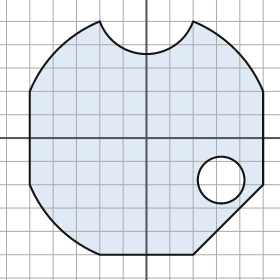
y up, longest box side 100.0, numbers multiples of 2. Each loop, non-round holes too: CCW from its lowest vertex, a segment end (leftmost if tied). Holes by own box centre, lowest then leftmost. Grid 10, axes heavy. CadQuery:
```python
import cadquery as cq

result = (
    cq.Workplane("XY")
    .moveTo(-20.0, -50.0)
    .lineTo(20.0, -50.0)
    .lineTo(50.0, -20.0)
    .lineTo(50.0, 20.0)
    .threePointArc((38.0, 38.0), (20.0, 50.0))
    .threePointArc((0.0, 36.0), (-20.0, 50.0))
    .threePointArc((-38.0, 38.0), (-50.0, 20.0))
    .lineTo(-50.0, -20.0)
    .threePointArc((-38.0, -38.0), (-20.0, -50.0))
    .close()
    .moveTo(32.0, -18.0)
    .circle(10.0)
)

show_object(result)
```